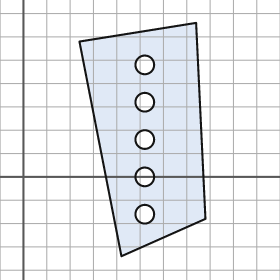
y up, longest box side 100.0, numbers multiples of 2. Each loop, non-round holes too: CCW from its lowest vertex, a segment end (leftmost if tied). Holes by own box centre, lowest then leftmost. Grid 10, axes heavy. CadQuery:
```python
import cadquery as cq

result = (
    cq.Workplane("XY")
    .moveTo(42.0, -34.0)
    .lineTo(78.0, -18.0)
    .lineTo(74.0, 66.0)
    .lineTo(24.0, 58.0)
    .close()
    .moveTo(52.0, -16.0)
    .circle(4.0)
    .moveTo(52.0, 0.0)
    .circle(4.0)
    .moveTo(52.0, 16.0)
    .circle(4.0)
    .moveTo(52.0, 32.0)
    .circle(4.0)
    .moveTo(52.0, 48.0)
    .circle(4.0)
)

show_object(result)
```